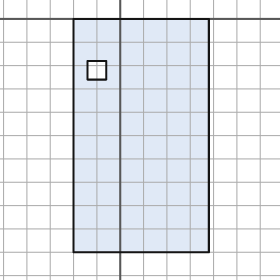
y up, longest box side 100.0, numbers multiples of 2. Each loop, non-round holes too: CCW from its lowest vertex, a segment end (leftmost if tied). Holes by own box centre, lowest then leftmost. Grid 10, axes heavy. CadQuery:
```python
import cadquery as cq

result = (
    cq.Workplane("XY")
    .moveTo(-20.0, -100.0)
    .lineTo(38.0, -100.0)
    .lineTo(38.0, 0.0)
    .lineTo(-20.0, 0.0)
    .close()
    .moveTo(-14.0, -26.0)
    .lineTo(-6.0, -26.0)
    .lineTo(-6.0, -18.0)
    .lineTo(-14.0, -18.0)
    .close()
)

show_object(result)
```